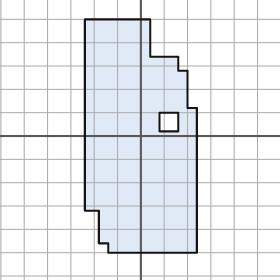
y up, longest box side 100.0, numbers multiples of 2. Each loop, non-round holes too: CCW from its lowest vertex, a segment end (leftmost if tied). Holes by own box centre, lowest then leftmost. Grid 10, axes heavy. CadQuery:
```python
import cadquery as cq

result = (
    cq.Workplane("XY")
    .moveTo(-14.0, -50.0)
    .lineTo(24.0, -50.0)
    .lineTo(24.0, 12.0)
    .lineTo(20.0, 12.0)
    .lineTo(20.0, 28.0)
    .lineTo(16.0, 28.0)
    .lineTo(16.0, 34.0)
    .lineTo(4.0, 34.0)
    .lineTo(4.0, 50.0)
    .lineTo(-24.0, 50.0)
    .lineTo(-24.0, -32.0)
    .lineTo(-18.0, -32.0)
    .lineTo(-18.0, -46.0)
    .lineTo(-14.0, -46.0)
    .close()
    .moveTo(8.0, 2.0)
    .lineTo(16.0, 2.0)
    .lineTo(16.0, 10.0)
    .lineTo(8.0, 10.0)
    .close()
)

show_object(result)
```